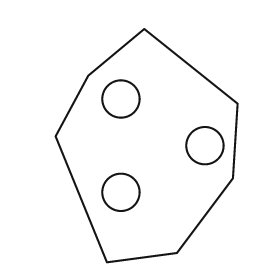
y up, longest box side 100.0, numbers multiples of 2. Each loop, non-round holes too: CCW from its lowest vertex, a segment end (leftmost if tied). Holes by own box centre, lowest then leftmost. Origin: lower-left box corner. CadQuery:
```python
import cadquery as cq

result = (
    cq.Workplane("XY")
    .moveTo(22.0, 0.0)
    .lineTo(52.0, 4.0)
    .lineTo(76.0, 36.0)
    .lineTo(78.0, 68.0)
    .lineTo(38.0, 100.0)
    .lineTo(14.0, 80.0)
    .lineTo(0.0, 54.0)
    .close()
    .moveTo(28.0, 30.0)
    .circle(8.0)
    .moveTo(64.0, 50.0)
    .circle(8.0)
    .moveTo(28.0, 70.0)
    .circle(8.0)
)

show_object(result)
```